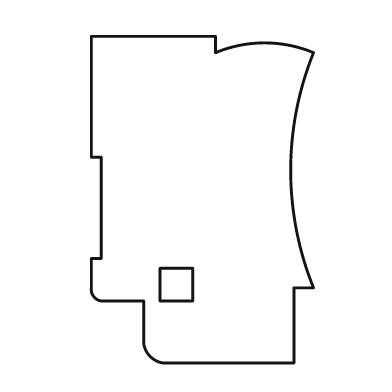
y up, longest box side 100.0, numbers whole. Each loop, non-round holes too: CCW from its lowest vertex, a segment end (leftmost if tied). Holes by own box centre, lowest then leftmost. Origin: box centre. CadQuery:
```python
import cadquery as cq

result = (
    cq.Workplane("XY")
    .moveTo(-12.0, -50.0)
    .lineTo(28.0, -50.0)
    .lineTo(28.0, -27.0)
    .lineTo(34.0, -27.0)
    .threePointArc((27.0, 9.0), (34.0, 45.0))
    .threePointArc((19.0, 48.0), (4.0, 45.0))
    .lineTo(4.0, 50.0)
    .lineTo(-34.0, 50.0)
    .lineTo(-34.0, 13.0)
    .lineTo(-31.0, 13.0)
    .lineTo(-31.0, -18.0)
    .lineTo(-34.0, -18.0)
    .lineTo(-34.0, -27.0)
    .threePointArc((-33.0, -30.0), (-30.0, -31.0))
    .lineTo(-18.0, -31.0)
    .lineTo(-18.0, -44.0)
    .threePointArc((-16.0, -48.0), (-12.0, -50.0))
    .close()
    .moveTo(-13.0, -31.0)
    .lineTo(-3.0, -31.0)
    .lineTo(-3.0, -21.0)
    .lineTo(-13.0, -21.0)
    .close()
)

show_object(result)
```